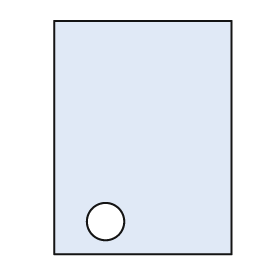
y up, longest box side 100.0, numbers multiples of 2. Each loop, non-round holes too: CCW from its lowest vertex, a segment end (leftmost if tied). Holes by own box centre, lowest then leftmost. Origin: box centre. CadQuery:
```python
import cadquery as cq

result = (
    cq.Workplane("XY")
    .moveTo(-38.0, -50.0)
    .lineTo(38.0, -50.0)
    .lineTo(38.0, 50.0)
    .lineTo(-38.0, 50.0)
    .close()
    .moveTo(-16.0, -36.0)
    .circle(8.0)
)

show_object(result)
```